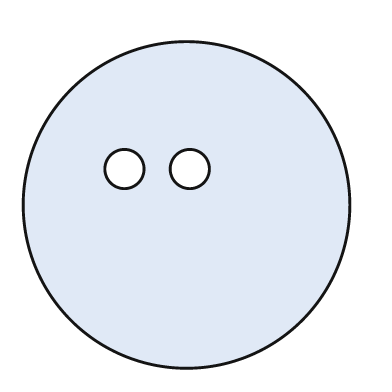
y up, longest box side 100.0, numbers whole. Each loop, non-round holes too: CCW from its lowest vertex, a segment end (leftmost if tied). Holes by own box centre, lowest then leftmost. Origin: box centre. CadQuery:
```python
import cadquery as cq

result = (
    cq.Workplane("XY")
    .moveTo(0.0, 0.0)
    .circle(50.0)
    .moveTo(-19.0, 11.0)
    .circle(6.0)
    .moveTo(1.0, 11.0)
    .circle(6.0)
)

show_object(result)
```